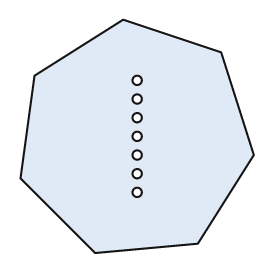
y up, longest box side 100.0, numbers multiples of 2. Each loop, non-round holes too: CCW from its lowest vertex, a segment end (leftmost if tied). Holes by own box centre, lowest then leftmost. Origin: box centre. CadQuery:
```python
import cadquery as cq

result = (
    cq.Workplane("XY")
    .moveTo(-18.0, -50.0)
    .lineTo(26.0, -46.0)
    .lineTo(50.0, -8.0)
    .lineTo(36.0, 36.0)
    .lineTo(-6.0, 50.0)
    .lineTo(-44.0, 26.0)
    .lineTo(-50.0, -18.0)
    .close()
    .moveTo(0.0, -24.0)
    .circle(2.0)
    .moveTo(0.0, -16.0)
    .circle(2.0)
    .moveTo(0.0, -8.0)
    .circle(2.0)
    .moveTo(0.0, 0.0)
    .circle(2.0)
    .moveTo(0.0, 8.0)
    .circle(2.0)
    .moveTo(0.0, 16.0)
    .circle(2.0)
    .moveTo(0.0, 24.0)
    .circle(2.0)
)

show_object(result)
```